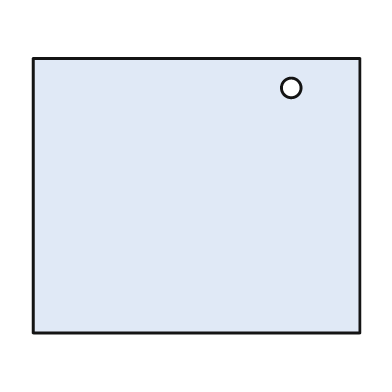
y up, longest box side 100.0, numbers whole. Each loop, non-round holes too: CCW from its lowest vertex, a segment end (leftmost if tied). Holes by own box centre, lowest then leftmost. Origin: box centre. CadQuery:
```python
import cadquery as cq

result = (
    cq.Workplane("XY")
    .moveTo(-50.0, -42.0)
    .lineTo(50.0, -42.0)
    .lineTo(50.0, 42.0)
    .lineTo(-50.0, 42.0)
    .close()
    .moveTo(29.0, 33.0)
    .circle(3.0)
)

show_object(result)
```